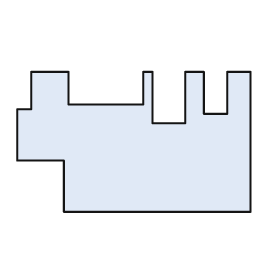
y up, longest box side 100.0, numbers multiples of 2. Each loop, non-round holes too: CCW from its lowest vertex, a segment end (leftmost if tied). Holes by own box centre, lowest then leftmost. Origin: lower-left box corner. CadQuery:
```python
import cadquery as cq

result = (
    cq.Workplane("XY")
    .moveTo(20.0, 0.0)
    .lineTo(100.0, 0.0)
    .lineTo(100.0, 60.0)
    .lineTo(90.0, 60.0)
    .lineTo(90.0, 42.0)
    .lineTo(80.0, 42.0)
    .lineTo(80.0, 60.0)
    .lineTo(72.0, 60.0)
    .lineTo(72.0, 38.0)
    .lineTo(58.0, 38.0)
    .lineTo(58.0, 60.0)
    .lineTo(54.0, 60.0)
    .lineTo(54.0, 46.0)
    .lineTo(22.0, 46.0)
    .lineTo(22.0, 60.0)
    .lineTo(6.0, 60.0)
    .lineTo(6.0, 44.0)
    .lineTo(0.0, 44.0)
    .lineTo(0.0, 22.0)
    .lineTo(20.0, 22.0)
    .close()
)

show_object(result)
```